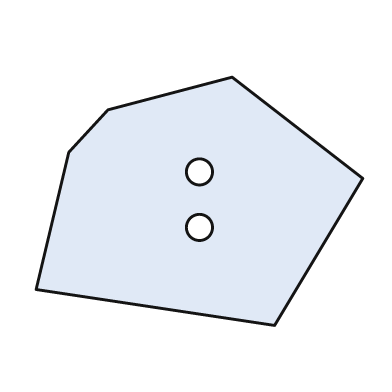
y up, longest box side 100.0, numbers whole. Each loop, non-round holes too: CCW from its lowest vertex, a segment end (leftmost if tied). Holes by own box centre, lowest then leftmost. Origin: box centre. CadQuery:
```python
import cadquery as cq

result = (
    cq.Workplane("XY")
    .moveTo(23.0, -38.0)
    .lineTo(50.0, 7.0)
    .lineTo(10.0, 38.0)
    .lineTo(-28.0, 28.0)
    .lineTo(-40.0, 15.0)
    .lineTo(-50.0, -27.0)
    .close()
    .moveTo(0.0, -8.0)
    .circle(4.0)
    .moveTo(0.0, 9.0)
    .circle(4.0)
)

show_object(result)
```